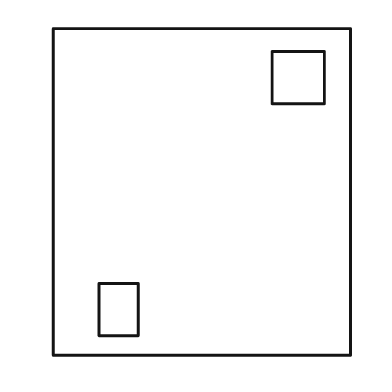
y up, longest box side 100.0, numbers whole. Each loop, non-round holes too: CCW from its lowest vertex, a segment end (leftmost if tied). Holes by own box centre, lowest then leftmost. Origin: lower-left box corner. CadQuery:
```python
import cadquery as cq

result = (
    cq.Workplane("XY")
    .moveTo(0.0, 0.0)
    .lineTo(91.0, 0.0)
    .lineTo(91.0, 100.0)
    .lineTo(0.0, 100.0)
    .close()
    .moveTo(14.0, 6.0)
    .lineTo(26.0, 6.0)
    .lineTo(26.0, 22.0)
    .lineTo(14.0, 22.0)
    .close()
    .moveTo(67.0, 77.0)
    .lineTo(83.0, 77.0)
    .lineTo(83.0, 93.0)
    .lineTo(67.0, 93.0)
    .close()
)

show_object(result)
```